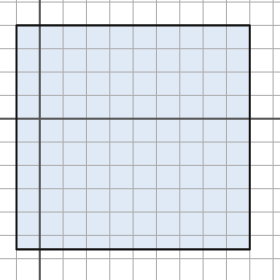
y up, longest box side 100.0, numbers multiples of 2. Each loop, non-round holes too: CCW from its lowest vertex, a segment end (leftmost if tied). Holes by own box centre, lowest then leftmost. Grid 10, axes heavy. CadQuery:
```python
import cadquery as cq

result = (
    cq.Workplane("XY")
    .moveTo(-10.0, -56.0)
    .lineTo(90.0, -56.0)
    .lineTo(90.0, 40.0)
    .lineTo(-10.0, 40.0)
    .close()
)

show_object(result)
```